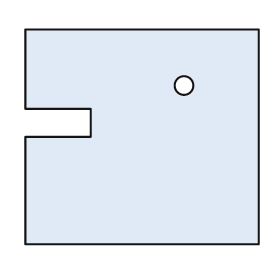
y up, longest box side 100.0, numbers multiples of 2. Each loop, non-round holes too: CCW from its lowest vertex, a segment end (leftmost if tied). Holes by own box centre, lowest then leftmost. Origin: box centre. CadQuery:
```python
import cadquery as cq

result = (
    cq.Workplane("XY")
    .moveTo(-50.0, -46.0)
    .lineTo(50.0, -46.0)
    .lineTo(50.0, 46.0)
    .lineTo(-50.0, 46.0)
    .lineTo(-50.0, 12.0)
    .lineTo(-22.0, 12.0)
    .lineTo(-22.0, 0.0)
    .lineTo(-50.0, 0.0)
    .close()
    .moveTo(18.0, 22.0)
    .circle(4.0)
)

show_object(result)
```